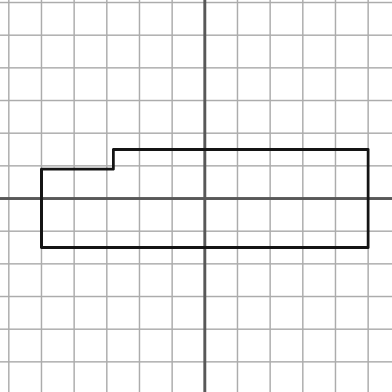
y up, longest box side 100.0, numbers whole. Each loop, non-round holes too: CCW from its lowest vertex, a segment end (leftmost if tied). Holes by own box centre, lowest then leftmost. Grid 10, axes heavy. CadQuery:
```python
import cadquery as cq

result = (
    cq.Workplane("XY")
    .moveTo(-50.0, -15.0)
    .lineTo(50.0, -15.0)
    .lineTo(50.0, 15.0)
    .lineTo(-28.0, 15.0)
    .lineTo(-28.0, 9.0)
    .lineTo(-50.0, 9.0)
    .close()
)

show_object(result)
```